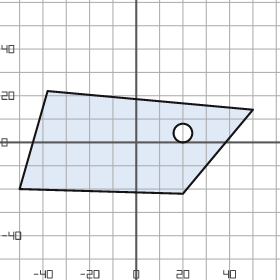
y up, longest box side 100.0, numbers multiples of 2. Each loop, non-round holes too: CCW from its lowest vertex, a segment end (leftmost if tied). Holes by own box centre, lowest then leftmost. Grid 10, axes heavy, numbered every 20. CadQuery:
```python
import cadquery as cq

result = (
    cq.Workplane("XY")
    .moveTo(20.0, -22.0)
    .lineTo(50.0, 14.0)
    .lineTo(-38.0, 22.0)
    .lineTo(-50.0, -20.0)
    .close()
    .moveTo(20.0, 4.0)
    .circle(4.0)
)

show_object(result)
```